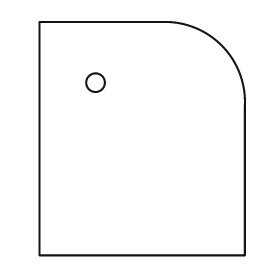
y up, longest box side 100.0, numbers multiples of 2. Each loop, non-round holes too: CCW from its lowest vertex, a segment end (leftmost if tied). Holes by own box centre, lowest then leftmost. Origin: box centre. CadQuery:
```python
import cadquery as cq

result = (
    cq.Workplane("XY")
    .moveTo(-44.0, -50.0)
    .lineTo(44.0, -50.0)
    .lineTo(44.0, 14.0)
    .threePointArc((34.0, 40.0), (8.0, 50.0))
    .lineTo(-44.0, 50.0)
    .close()
    .moveTo(-20.0, 24.0)
    .circle(4.0)
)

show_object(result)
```